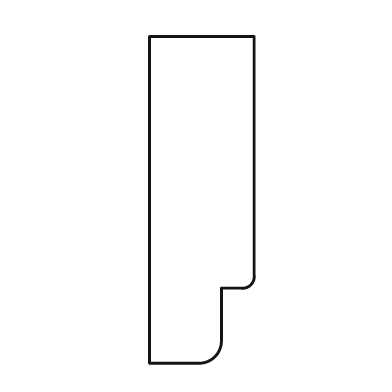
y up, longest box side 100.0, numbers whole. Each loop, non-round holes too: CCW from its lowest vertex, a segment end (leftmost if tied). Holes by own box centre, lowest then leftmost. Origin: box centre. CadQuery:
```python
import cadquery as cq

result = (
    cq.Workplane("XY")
    .moveTo(-16.0, -50.0)
    .lineTo(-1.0, -50.0)
    .threePointArc((4.0, -48.0), (6.0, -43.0))
    .lineTo(6.0, -27.0)
    .lineTo(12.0, -27.0)
    .threePointArc((15.0, -26.0), (16.0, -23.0))
    .lineTo(16.0, 50.0)
    .lineTo(-16.0, 50.0)
    .close()
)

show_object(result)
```